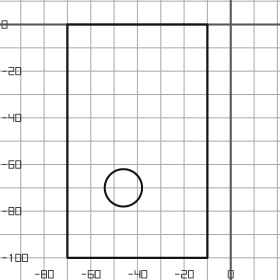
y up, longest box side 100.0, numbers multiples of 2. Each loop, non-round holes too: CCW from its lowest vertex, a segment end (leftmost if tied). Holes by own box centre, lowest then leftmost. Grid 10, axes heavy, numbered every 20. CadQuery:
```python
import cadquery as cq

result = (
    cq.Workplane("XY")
    .moveTo(-70.0, -100.0)
    .lineTo(-10.0, -100.0)
    .lineTo(-10.0, 0.0)
    .lineTo(-70.0, 0.0)
    .close()
    .moveTo(-46.0, -70.0)
    .circle(8.0)
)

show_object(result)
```